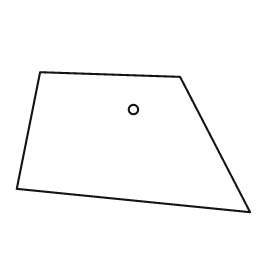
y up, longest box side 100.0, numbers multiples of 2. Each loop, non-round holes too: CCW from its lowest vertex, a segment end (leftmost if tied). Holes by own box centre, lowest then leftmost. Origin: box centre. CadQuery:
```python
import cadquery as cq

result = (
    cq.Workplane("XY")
    .moveTo(50.0, -30.0)
    .lineTo(20.0, 28.0)
    .lineTo(-40.0, 30.0)
    .lineTo(-50.0, -20.0)
    .close()
    .moveTo(0.0, 14.0)
    .circle(2.0)
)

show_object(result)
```